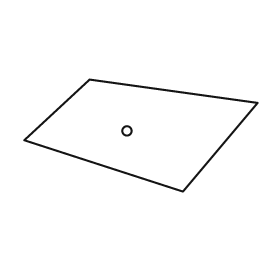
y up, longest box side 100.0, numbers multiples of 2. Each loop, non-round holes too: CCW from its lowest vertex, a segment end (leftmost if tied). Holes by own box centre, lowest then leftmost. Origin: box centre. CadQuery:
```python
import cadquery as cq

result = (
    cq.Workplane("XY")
    .moveTo(18.0, -24.0)
    .lineTo(50.0, 14.0)
    .lineTo(-22.0, 24.0)
    .lineTo(-50.0, -2.0)
    .close()
    .moveTo(-6.0, 2.0)
    .circle(2.0)
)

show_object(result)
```